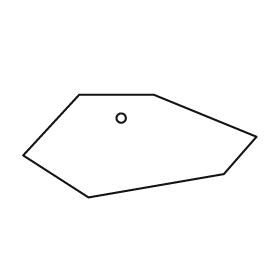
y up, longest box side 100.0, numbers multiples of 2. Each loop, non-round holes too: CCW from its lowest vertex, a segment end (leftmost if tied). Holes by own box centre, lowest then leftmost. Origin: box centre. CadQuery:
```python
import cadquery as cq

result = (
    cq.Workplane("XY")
    .moveTo(-22.0, -22.0)
    .lineTo(36.0, -12.0)
    .lineTo(50.0, 4.0)
    .lineTo(6.0, 22.0)
    .lineTo(-26.0, 22.0)
    .lineTo(-50.0, -4.0)
    .close()
    .moveTo(-8.0, 12.0)
    .circle(2.0)
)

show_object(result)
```